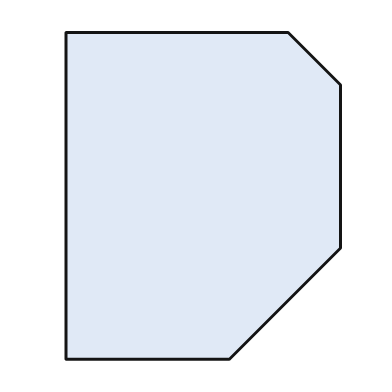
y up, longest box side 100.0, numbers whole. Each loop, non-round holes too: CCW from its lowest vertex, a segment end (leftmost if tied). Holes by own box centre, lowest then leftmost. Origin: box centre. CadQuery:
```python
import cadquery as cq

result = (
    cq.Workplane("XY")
    .moveTo(-42.0, -50.0)
    .lineTo(8.0, -50.0)
    .lineTo(42.0, -16.0)
    .lineTo(42.0, 34.0)
    .lineTo(26.0, 50.0)
    .lineTo(-42.0, 50.0)
    .close()
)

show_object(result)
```